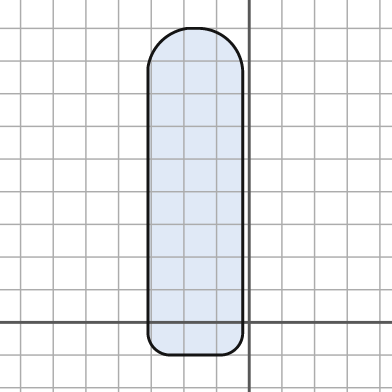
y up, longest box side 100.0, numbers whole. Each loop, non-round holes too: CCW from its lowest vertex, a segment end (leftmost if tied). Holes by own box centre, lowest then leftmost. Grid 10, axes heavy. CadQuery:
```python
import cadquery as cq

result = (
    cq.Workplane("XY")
    .moveTo(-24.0, -10.0)
    .lineTo(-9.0, -10.0)
    .threePointArc((-4.0, -8.0), (-2.0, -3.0))
    .lineTo(-2.0, 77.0)
    .threePointArc((-6.0, 86.0), (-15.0, 90.0))
    .lineTo(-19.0, 90.0)
    .threePointArc((-27.0, 86.0), (-31.0, 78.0))
    .lineTo(-31.0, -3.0)
    .threePointArc((-29.0, -8.0), (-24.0, -10.0))
    .close()
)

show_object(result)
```